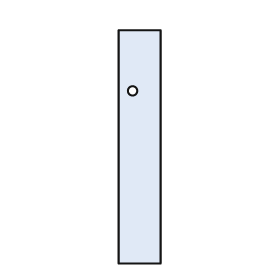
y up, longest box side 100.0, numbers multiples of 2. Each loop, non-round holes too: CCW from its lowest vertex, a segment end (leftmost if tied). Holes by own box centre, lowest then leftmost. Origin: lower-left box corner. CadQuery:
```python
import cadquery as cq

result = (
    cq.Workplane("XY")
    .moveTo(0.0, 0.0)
    .lineTo(18.0, 0.0)
    .lineTo(18.0, 100.0)
    .lineTo(0.0, 100.0)
    .close()
    .moveTo(6.0, 74.0)
    .circle(2.0)
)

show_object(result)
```